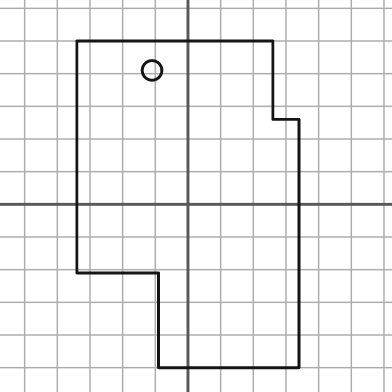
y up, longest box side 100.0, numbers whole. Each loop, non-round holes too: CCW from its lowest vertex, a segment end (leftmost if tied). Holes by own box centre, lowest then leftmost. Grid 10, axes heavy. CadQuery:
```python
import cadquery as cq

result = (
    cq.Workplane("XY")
    .moveTo(-9.0, -50.0)
    .lineTo(34.0, -50.0)
    .lineTo(34.0, 26.0)
    .lineTo(26.0, 26.0)
    .lineTo(26.0, 50.0)
    .lineTo(-34.0, 50.0)
    .lineTo(-34.0, -21.0)
    .lineTo(-9.0, -21.0)
    .close()
    .moveTo(-11.0, 41.0)
    .circle(3.0)
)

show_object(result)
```